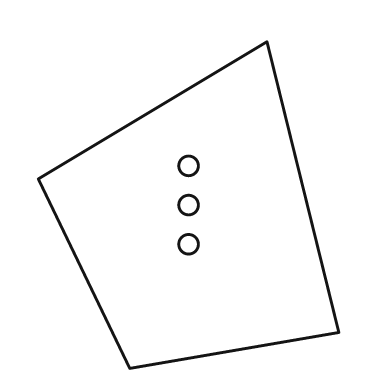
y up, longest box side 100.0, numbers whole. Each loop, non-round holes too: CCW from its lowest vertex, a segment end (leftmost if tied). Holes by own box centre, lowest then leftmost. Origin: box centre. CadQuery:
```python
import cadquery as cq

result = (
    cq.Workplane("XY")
    .moveTo(-18.0, -50.0)
    .lineTo(46.0, -39.0)
    .lineTo(24.0, 50.0)
    .lineTo(-46.0, 8.0)
    .close()
    .moveTo(0.0, -12.0)
    .circle(3.0)
    .moveTo(0.0, 0.0)
    .circle(3.0)
    .moveTo(0.0, 12.0)
    .circle(3.0)
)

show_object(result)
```